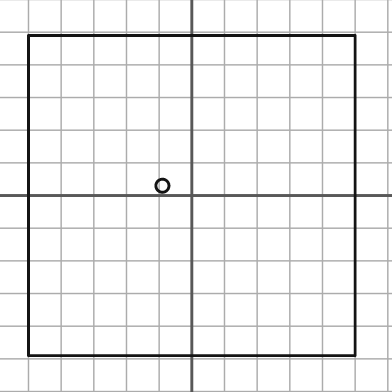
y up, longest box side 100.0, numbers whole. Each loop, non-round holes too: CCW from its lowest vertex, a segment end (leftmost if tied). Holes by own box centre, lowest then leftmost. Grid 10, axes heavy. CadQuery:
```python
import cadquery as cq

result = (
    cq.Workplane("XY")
    .moveTo(-50.0, -49.0)
    .lineTo(50.0, -49.0)
    .lineTo(50.0, 49.0)
    .lineTo(-50.0, 49.0)
    .close()
    .moveTo(-9.0, 3.0)
    .circle(2.0)
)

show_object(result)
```